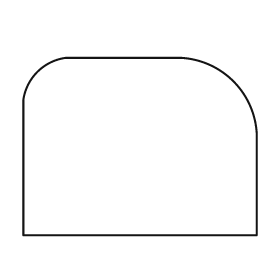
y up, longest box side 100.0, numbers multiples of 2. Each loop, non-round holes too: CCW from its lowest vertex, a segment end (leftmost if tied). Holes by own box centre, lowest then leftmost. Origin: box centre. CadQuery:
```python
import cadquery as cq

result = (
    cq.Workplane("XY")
    .moveTo(-50.0, -38.0)
    .lineTo(50.0, -38.0)
    .lineTo(50.0, 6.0)
    .threePointArc((40.0, 28.0), (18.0, 38.0))
    .lineTo(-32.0, 38.0)
    .threePointArc((-44.0, 32.0), (-50.0, 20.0))
    .close()
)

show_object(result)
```